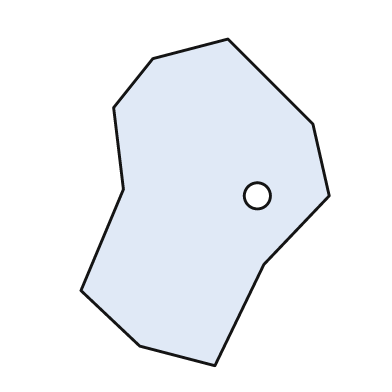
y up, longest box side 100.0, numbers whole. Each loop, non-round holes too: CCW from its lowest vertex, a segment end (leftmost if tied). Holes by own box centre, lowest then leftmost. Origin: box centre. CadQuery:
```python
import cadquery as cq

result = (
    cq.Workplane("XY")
    .moveTo(3.0, -50.0)
    .lineTo(18.0, -19.0)
    .lineTo(38.0, 2.0)
    .lineTo(33.0, 24.0)
    .lineTo(7.0, 50.0)
    .lineTo(-16.0, 44.0)
    .lineTo(-28.0, 29.0)
    .lineTo(-25.0, 4.0)
    .lineTo(-38.0, -27.0)
    .lineTo(-20.0, -44.0)
    .close()
    .moveTo(16.0, 2.0)
    .circle(4.0)
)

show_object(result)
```